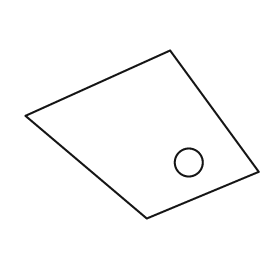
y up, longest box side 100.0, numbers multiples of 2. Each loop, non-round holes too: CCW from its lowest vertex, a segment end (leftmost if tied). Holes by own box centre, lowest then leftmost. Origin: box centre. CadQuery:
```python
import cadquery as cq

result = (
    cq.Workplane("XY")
    .moveTo(2.0, -36.0)
    .lineTo(50.0, -16.0)
    .lineTo(12.0, 36.0)
    .lineTo(-50.0, 8.0)
    .close()
    .moveTo(20.0, -12.0)
    .circle(6.0)
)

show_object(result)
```